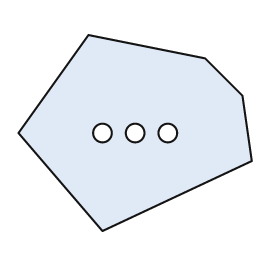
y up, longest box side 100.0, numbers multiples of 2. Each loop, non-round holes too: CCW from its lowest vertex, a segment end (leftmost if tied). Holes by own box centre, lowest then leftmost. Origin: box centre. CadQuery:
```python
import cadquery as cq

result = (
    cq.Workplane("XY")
    .moveTo(-14.0, -42.0)
    .lineTo(50.0, -12.0)
    .lineTo(46.0, 16.0)
    .lineTo(30.0, 32.0)
    .lineTo(-20.0, 42.0)
    .lineTo(-50.0, 0.0)
    .close()
    .moveTo(-14.0, 0.0)
    .circle(4.0)
    .moveTo(0.0, 0.0)
    .circle(4.0)
    .moveTo(14.0, 0.0)
    .circle(4.0)
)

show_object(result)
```